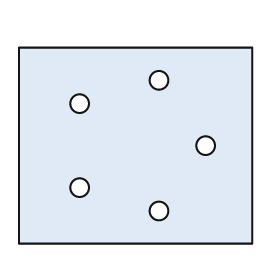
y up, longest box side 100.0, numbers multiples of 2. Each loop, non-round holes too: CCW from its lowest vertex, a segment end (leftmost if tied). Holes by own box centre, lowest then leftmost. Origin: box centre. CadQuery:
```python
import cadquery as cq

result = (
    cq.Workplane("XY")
    .moveTo(-50.0, -42.0)
    .lineTo(50.0, -42.0)
    .lineTo(50.0, 42.0)
    .lineTo(-50.0, 42.0)
    .close()
    .moveTo(10.0, -28.0)
    .circle(4.0)
    .moveTo(-24.0, -18.0)
    .circle(4.0)
    .moveTo(30.0, 0.0)
    .circle(4.0)
    .moveTo(-24.0, 18.0)
    .circle(4.0)
    .moveTo(10.0, 28.0)
    .circle(4.0)
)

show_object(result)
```